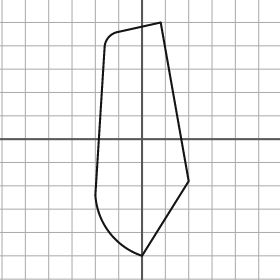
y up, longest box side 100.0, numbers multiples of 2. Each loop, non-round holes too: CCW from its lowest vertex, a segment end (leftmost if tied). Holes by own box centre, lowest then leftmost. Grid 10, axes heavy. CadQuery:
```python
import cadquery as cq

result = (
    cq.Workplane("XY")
    .moveTo(0.0, -50.0)
    .lineTo(20.0, -18.0)
    .lineTo(8.0, 50.0)
    .lineTo(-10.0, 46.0)
    .threePointArc((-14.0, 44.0), (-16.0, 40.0))
    .lineTo(-20.0, -24.0)
    .threePointArc((-14.0, -40.0), (0.0, -50.0))
    .close()
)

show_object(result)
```